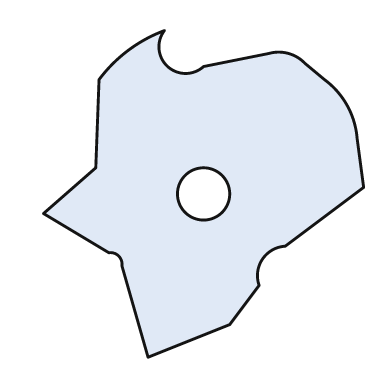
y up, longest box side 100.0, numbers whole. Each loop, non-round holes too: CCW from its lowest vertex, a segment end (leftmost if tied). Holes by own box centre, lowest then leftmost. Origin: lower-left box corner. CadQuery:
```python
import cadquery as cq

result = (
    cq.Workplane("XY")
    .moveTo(32.0, 0.0)
    .lineTo(57.0, 10.0)
    .lineTo(66.0, 22.0)
    .threePointArc((67.0, 30.0), (74.0, 34.0))
    .lineTo(98.0, 52.0)
    .lineTo(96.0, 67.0)
    .threePointArc((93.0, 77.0), (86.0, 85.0))
    .lineTo(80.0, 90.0)
    .threePointArc((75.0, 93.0), (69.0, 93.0))
    .lineTo(49.0, 89.0)
    .threePointArc((38.0, 89.0), (37.0, 100.0))
    .threePointArc((26.0, 94.0), (17.0, 85.0))
    .lineTo(16.0, 58.0)
    .lineTo(0.0, 44.0)
    .lineTo(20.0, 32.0)
    .threePointArc((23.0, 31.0), (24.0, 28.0))
    .close()
    .moveTo(49.0, 50.0)
    .circle(8.0)
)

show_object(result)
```